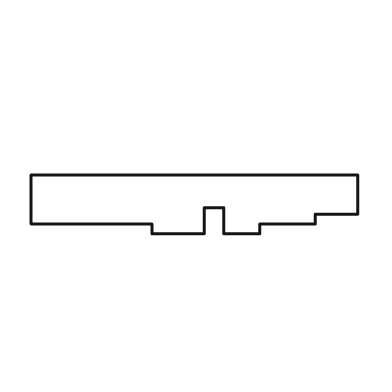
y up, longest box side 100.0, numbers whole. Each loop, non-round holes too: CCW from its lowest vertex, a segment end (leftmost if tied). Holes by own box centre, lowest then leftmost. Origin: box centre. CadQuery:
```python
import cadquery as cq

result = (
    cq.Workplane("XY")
    .moveTo(-13.0, -9.0)
    .lineTo(3.0, -9.0)
    .lineTo(3.0, -1.0)
    .lineTo(9.0, -1.0)
    .lineTo(9.0, -9.0)
    .lineTo(20.0, -9.0)
    .lineTo(20.0, -6.0)
    .lineTo(37.0, -6.0)
    .lineTo(37.0, -3.0)
    .lineTo(50.0, -3.0)
    .lineTo(50.0, 9.0)
    .lineTo(-50.0, 9.0)
    .lineTo(-50.0, -6.0)
    .lineTo(-13.0, -6.0)
    .close()
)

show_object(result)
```